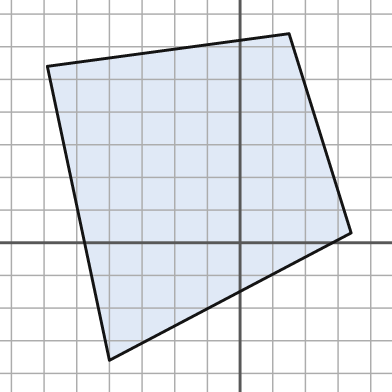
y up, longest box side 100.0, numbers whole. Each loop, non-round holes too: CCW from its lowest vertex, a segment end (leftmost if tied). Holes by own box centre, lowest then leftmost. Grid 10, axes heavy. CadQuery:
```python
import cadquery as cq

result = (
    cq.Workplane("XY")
    .moveTo(-40.0, -36.0)
    .lineTo(34.0, 3.0)
    .lineTo(15.0, 64.0)
    .lineTo(-59.0, 54.0)
    .close()
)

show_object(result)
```